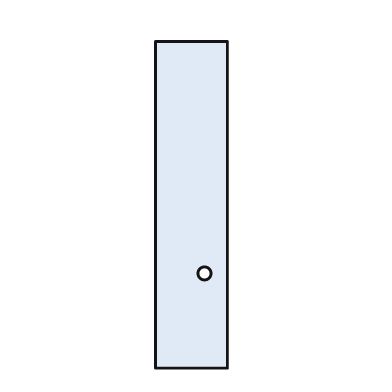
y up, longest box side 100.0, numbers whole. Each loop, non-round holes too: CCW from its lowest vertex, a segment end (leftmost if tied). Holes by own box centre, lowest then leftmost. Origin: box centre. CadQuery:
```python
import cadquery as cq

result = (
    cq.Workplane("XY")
    .moveTo(-11.0, -50.0)
    .lineTo(11.0, -50.0)
    .lineTo(11.0, 50.0)
    .lineTo(-11.0, 50.0)
    .close()
    .moveTo(4.0, -21.0)
    .circle(2.0)
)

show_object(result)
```